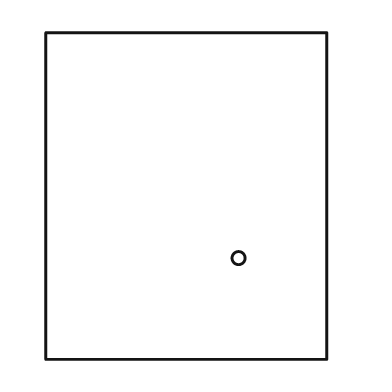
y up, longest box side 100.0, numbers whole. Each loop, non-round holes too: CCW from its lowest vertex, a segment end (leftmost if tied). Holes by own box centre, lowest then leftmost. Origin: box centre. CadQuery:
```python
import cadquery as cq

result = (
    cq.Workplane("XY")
    .moveTo(-43.0, -50.0)
    .lineTo(43.0, -50.0)
    .lineTo(43.0, 50.0)
    .lineTo(-43.0, 50.0)
    .close()
    .moveTo(16.0, -19.0)
    .circle(2.0)
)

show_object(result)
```